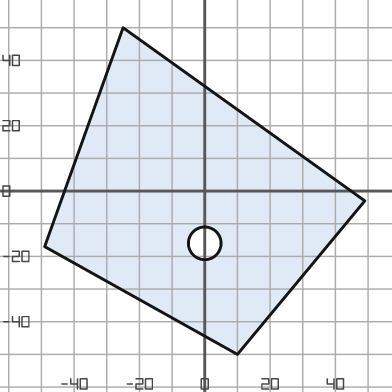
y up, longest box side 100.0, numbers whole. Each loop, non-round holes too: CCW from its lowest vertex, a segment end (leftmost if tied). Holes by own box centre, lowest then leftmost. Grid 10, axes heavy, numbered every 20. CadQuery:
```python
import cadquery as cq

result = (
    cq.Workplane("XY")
    .moveTo(10.0, -50.0)
    .lineTo(49.0, -3.0)
    .lineTo(-25.0, 50.0)
    .lineTo(-49.0, -17.0)
    .close()
    .moveTo(0.0, -16.0)
    .circle(5.0)
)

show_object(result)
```